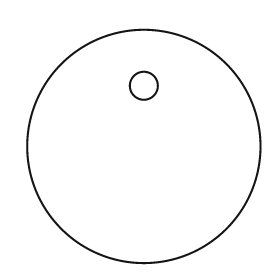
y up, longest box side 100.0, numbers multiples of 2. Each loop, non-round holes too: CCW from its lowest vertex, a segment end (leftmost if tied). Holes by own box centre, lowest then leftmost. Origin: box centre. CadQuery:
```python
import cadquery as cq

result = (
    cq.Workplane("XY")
    .moveTo(0.0, 0.0)
    .circle(50.0)
    .moveTo(0.0, 26.0)
    .circle(6.0)
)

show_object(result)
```